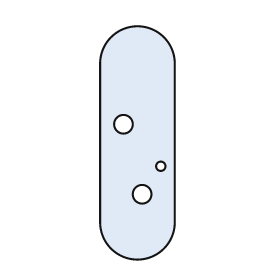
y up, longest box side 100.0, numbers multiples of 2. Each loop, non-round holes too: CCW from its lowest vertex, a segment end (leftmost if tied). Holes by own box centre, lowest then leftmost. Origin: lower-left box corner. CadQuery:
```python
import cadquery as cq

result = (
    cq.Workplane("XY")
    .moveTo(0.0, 16.0)
    .threePointArc((16.0, 0.0), (32.0, 16.0))
    .lineTo(32.0, 84.0)
    .threePointArc((16.0, 100.0), (0.0, 84.0))
    .close()
    .moveTo(18.0, 28.0)
    .circle(4.0)
    .moveTo(26.0, 40.0)
    .circle(2.0)
    .moveTo(10.0, 58.0)
    .circle(4.0)
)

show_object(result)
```